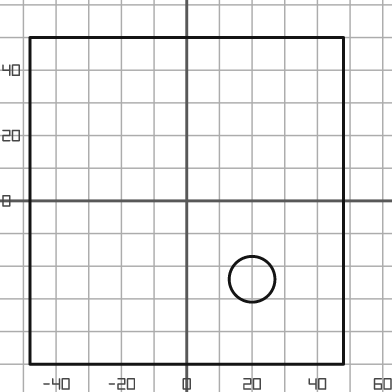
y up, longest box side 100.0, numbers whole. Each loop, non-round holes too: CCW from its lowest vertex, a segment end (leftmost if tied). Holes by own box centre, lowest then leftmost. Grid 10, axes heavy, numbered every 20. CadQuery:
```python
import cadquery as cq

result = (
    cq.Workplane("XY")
    .moveTo(-48.0, -50.0)
    .lineTo(48.0, -50.0)
    .lineTo(48.0, 50.0)
    .lineTo(-48.0, 50.0)
    .close()
    .moveTo(20.0, -24.0)
    .circle(7.0)
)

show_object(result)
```